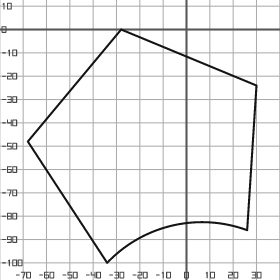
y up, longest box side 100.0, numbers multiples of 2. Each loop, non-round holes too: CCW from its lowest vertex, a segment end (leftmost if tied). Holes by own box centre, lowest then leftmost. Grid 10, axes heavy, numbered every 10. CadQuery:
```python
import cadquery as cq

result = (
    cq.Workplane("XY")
    .moveTo(-34.0, -100.0)
    .threePointArc((-6.0, -84.0), (26.0, -86.0))
    .lineTo(30.0, -24.0)
    .lineTo(-28.0, 0.0)
    .lineTo(-68.0, -48.0)
    .close()
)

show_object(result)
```